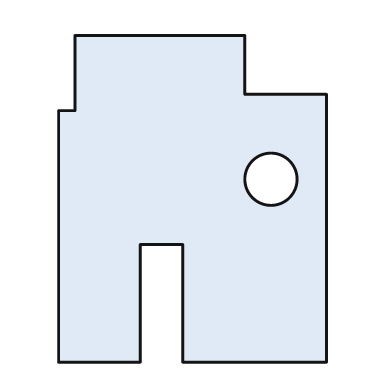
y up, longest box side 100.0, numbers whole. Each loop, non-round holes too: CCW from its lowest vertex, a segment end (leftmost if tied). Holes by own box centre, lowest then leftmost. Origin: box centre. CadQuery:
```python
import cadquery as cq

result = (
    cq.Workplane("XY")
    .moveTo(-41.0, -50.0)
    .lineTo(-16.0, -50.0)
    .lineTo(-16.0, -14.0)
    .lineTo(-3.0, -14.0)
    .lineTo(-3.0, -50.0)
    .lineTo(41.0, -50.0)
    .lineTo(41.0, 32.0)
    .lineTo(16.0, 32.0)
    .lineTo(16.0, 50.0)
    .lineTo(-36.0, 50.0)
    .lineTo(-36.0, 27.0)
    .lineTo(-41.0, 27.0)
    .close()
    .moveTo(24.0, 6.0)
    .circle(8.0)
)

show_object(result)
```